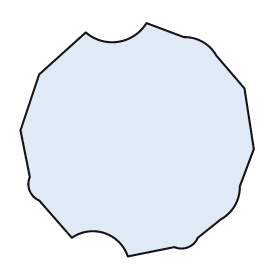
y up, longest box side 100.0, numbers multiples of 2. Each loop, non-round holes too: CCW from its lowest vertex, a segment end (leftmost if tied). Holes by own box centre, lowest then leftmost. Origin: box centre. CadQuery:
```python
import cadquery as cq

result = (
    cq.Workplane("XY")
    .moveTo(-4.0, -50.0)
    .lineTo(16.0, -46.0)
    .threePointArc((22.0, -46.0), (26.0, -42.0))
    .lineTo(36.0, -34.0)
    .threePointArc((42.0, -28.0), (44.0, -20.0))
    .lineTo(50.0, -4.0)
    .lineTo(46.0, 22.0)
    .lineTo(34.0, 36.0)
    .threePointArc((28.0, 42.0), (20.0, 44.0))
    .lineTo(4.0, 50.0)
    .threePointArc((-8.0, 42.0), (-22.0, 46.0))
    .lineTo(-42.0, 28.0)
    .lineTo(-50.0, 4.0)
    .lineTo(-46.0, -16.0)
    .threePointArc((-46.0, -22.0), (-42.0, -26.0))
    .lineTo(-28.0, -42.0)
    .threePointArc((-14.0, -40.0), (-4.0, -50.0))
    .close()
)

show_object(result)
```